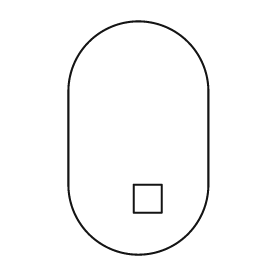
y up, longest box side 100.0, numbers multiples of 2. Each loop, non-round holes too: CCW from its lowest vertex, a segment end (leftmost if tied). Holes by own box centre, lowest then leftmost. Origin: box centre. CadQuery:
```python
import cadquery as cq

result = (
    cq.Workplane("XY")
    .moveTo(-30.0, -20.0)
    .threePointArc((0.0, -50.0), (30.0, -20.0))
    .lineTo(30.0, 20.0)
    .threePointArc((0.0, 50.0), (-30.0, 20.0))
    .close()
    .moveTo(-2.0, -32.0)
    .lineTo(10.0, -32.0)
    .lineTo(10.0, -20.0)
    .lineTo(-2.0, -20.0)
    .close()
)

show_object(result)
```